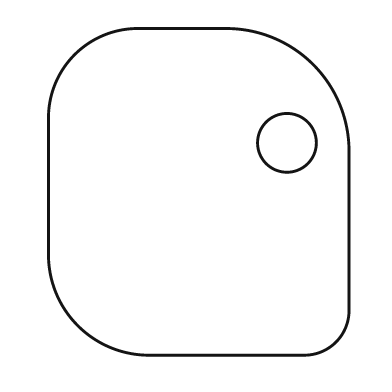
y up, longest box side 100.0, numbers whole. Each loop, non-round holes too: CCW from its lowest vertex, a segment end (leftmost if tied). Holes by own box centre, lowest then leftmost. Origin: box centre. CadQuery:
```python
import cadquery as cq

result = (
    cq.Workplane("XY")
    .moveTo(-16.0, -50.0)
    .lineTo(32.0, -50.0)
    .threePointArc((42.0, -46.0), (46.0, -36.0))
    .lineTo(46.0, 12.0)
    .threePointArc((35.0, 39.0), (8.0, 50.0))
    .lineTo(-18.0, 50.0)
    .threePointArc((-38.0, 42.0), (-46.0, 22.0))
    .lineTo(-46.0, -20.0)
    .threePointArc((-37.0, -41.0), (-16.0, -50.0))
    .close()
    .moveTo(27.0, 15.0)
    .circle(9.0)
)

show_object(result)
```